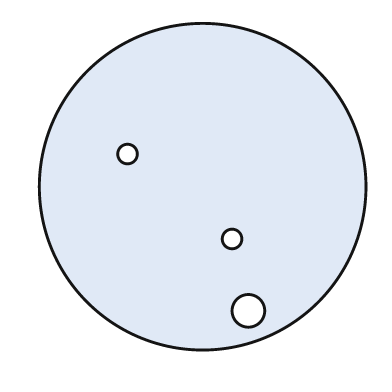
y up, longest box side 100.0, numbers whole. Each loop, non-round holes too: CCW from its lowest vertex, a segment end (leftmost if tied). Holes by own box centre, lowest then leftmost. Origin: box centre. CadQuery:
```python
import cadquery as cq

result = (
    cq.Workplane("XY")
    .moveTo(0.0, 0.0)
    .circle(50.0)
    .moveTo(14.0, -38.0)
    .circle(5.0)
    .moveTo(9.0, -16.0)
    .circle(3.0)
    .moveTo(-23.0, 10.0)
    .circle(3.0)
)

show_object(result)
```